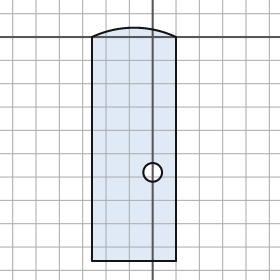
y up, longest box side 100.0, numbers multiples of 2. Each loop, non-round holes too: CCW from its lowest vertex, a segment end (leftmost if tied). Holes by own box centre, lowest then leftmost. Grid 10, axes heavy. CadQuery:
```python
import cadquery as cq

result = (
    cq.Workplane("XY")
    .moveTo(-26.0, -96.0)
    .lineTo(10.0, -96.0)
    .lineTo(10.0, 0.0)
    .threePointArc((-8.0, 4.0), (-26.0, 0.0))
    .close()
    .moveTo(0.0, -58.0)
    .circle(4.0)
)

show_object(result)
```